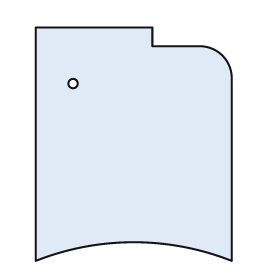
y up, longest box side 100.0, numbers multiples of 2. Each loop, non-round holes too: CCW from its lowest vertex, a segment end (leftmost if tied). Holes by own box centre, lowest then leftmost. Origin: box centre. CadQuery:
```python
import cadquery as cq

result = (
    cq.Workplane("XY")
    .moveTo(-42.0, -50.0)
    .threePointArc((0.0, -42.0), (42.0, -50.0))
    .lineTo(42.0, 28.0)
    .threePointArc((38.0, 38.0), (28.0, 42.0))
    .lineTo(8.0, 42.0)
    .lineTo(8.0, 50.0)
    .lineTo(-42.0, 50.0)
    .close()
    .moveTo(-26.0, 26.0)
    .circle(2.0)
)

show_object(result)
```